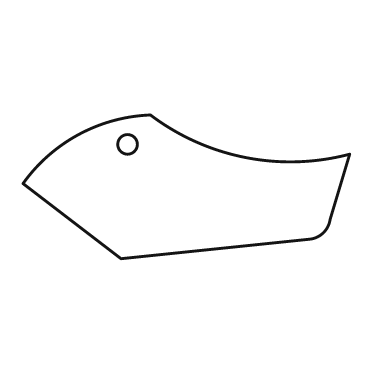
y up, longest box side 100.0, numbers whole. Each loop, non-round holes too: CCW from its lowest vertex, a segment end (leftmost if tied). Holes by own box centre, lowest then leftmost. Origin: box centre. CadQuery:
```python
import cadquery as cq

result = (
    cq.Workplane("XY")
    .moveTo(-20.0, -22.0)
    .lineTo(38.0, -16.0)
    .threePointArc((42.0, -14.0), (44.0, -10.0))
    .lineTo(50.0, 10.0)
    .threePointArc((18.0, 9.0), (-11.0, 22.0))
    .threePointArc((-33.0, 16.0), (-50.0, 1.0))
    .close()
    .moveTo(-18.0, 13.0)
    .circle(3.0)
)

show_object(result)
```